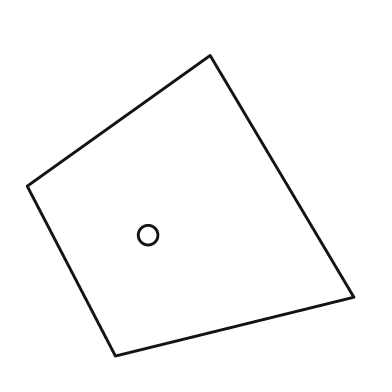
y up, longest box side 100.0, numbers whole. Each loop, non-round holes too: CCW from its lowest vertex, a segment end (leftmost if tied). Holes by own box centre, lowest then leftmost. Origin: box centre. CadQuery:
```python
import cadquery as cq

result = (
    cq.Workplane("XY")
    .moveTo(-23.0, -46.0)
    .lineTo(50.0, -28.0)
    .lineTo(6.0, 46.0)
    .lineTo(-50.0, 6.0)
    .close()
    .moveTo(-13.0, -9.0)
    .circle(3.0)
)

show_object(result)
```